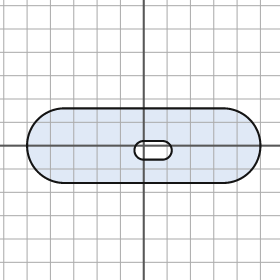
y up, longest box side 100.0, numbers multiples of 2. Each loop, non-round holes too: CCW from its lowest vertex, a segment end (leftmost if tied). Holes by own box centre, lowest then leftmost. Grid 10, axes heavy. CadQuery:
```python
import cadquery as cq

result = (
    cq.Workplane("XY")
    .moveTo(-34.0, -16.0)
    .lineTo(34.0, -16.0)
    .threePointArc((50.0, 0.0), (34.0, 16.0))
    .lineTo(-34.0, 16.0)
    .threePointArc((-50.0, 0.0), (-34.0, -16.0))
    .close()
    .moveTo(0.0, -6.0)
    .lineTo(8.0, -6.0)
    .threePointArc((12.0, -2.0), (8.0, 2.0))
    .lineTo(0.0, 2.0)
    .threePointArc((-4.0, -2.0), (0.0, -6.0))
    .close()
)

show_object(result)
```